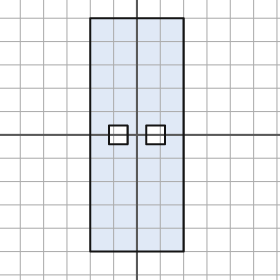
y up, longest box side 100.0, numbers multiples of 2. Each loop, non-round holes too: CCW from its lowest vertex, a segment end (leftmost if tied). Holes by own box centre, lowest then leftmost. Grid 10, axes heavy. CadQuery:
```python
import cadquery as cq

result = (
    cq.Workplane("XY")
    .moveTo(-20.0, -50.0)
    .lineTo(20.0, -50.0)
    .lineTo(20.0, 50.0)
    .lineTo(-20.0, 50.0)
    .close()
    .moveTo(-12.0, -4.0)
    .lineTo(-4.0, -4.0)
    .lineTo(-4.0, 4.0)
    .lineTo(-12.0, 4.0)
    .close()
    .moveTo(4.0, -4.0)
    .lineTo(12.0, -4.0)
    .lineTo(12.0, 4.0)
    .lineTo(4.0, 4.0)
    .close()
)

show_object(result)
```